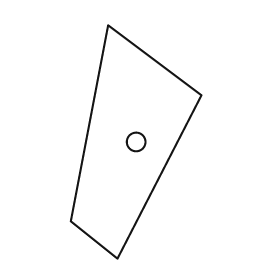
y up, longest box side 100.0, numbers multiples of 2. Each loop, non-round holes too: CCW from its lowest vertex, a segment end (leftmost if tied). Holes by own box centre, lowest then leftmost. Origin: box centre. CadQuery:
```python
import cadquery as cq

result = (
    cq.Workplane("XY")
    .moveTo(-8.0, -50.0)
    .lineTo(28.0, 20.0)
    .lineTo(-12.0, 50.0)
    .lineTo(-28.0, -34.0)
    .close()
    .moveTo(0.0, 0.0)
    .circle(4.0)
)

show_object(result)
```